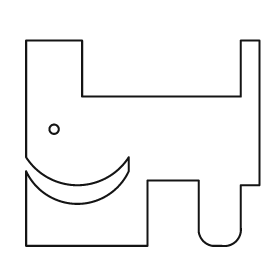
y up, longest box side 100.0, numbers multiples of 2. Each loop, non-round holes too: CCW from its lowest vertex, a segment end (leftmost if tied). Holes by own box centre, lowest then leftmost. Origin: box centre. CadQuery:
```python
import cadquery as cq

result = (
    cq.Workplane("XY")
    .moveTo(-50.0, -44.0)
    .lineTo(2.0, -44.0)
    .lineTo(2.0, -16.0)
    .lineTo(24.0, -16.0)
    .lineTo(24.0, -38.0)
    .threePointArc((26.0, -42.0), (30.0, -44.0))
    .lineTo(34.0, -44.0)
    .threePointArc((40.0, -42.0), (42.0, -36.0))
    .lineTo(42.0, -18.0)
    .lineTo(50.0, -18.0)
    .lineTo(50.0, 44.0)
    .lineTo(42.0, 44.0)
    .lineTo(42.0, 20.0)
    .lineTo(-26.0, 20.0)
    .lineTo(-26.0, 44.0)
    .lineTo(-50.0, 44.0)
    .lineTo(-50.0, -6.0)
    .threePointArc((-28.0, -18.0), (-6.0, -6.0))
    .lineTo(-6.0, -12.0)
    .threePointArc((-28.0, -26.0), (-50.0, -12.0))
    .close()
    .moveTo(-38.0, 6.0)
    .circle(2.0)
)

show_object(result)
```